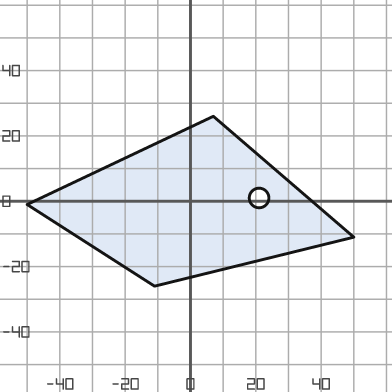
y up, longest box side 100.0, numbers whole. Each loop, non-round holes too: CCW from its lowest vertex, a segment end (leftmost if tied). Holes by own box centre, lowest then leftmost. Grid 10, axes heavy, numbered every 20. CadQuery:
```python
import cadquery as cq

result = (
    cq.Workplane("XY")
    .moveTo(-11.0, -26.0)
    .lineTo(50.0, -11.0)
    .lineTo(7.0, 26.0)
    .lineTo(-50.0, -1.0)
    .close()
    .moveTo(21.0, 1.0)
    .circle(3.0)
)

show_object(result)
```